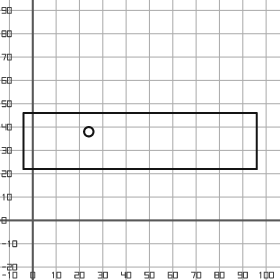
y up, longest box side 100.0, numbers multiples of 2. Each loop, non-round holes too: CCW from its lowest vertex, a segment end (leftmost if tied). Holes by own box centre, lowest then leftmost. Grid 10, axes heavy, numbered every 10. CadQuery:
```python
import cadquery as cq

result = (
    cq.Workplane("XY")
    .moveTo(-4.0, 22.0)
    .lineTo(96.0, 22.0)
    .lineTo(96.0, 46.0)
    .lineTo(-4.0, 46.0)
    .close()
    .moveTo(24.0, 38.0)
    .circle(2.0)
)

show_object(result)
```